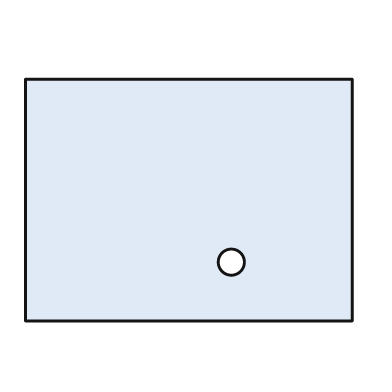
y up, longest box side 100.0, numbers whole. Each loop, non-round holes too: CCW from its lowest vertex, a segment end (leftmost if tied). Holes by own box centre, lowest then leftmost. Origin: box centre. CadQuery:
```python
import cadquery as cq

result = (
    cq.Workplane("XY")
    .moveTo(-50.0, -37.0)
    .lineTo(50.0, -37.0)
    .lineTo(50.0, 37.0)
    .lineTo(-50.0, 37.0)
    .close()
    .moveTo(13.0, -19.0)
    .circle(4.0)
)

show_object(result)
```